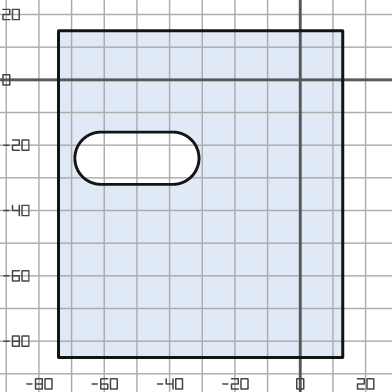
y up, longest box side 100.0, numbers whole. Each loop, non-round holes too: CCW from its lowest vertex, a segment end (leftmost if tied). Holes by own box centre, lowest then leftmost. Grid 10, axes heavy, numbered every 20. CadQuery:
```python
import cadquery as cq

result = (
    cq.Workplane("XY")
    .moveTo(-74.0, -85.0)
    .lineTo(13.0, -85.0)
    .lineTo(13.0, 15.0)
    .lineTo(-74.0, 15.0)
    .close()
    .moveTo(-61.0, -32.0)
    .lineTo(-39.0, -32.0)
    .threePointArc((-31.0, -24.0), (-39.0, -16.0))
    .lineTo(-61.0, -16.0)
    .threePointArc((-69.0, -24.0), (-61.0, -32.0))
    .close()
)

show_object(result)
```